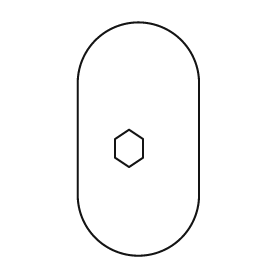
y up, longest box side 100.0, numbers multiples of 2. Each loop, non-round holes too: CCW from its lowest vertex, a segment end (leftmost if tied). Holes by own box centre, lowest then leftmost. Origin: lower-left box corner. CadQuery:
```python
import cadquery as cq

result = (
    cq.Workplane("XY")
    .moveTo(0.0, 26.0)
    .threePointArc((26.0, 0.0), (52.0, 26.0))
    .lineTo(52.0, 74.0)
    .threePointArc((26.0, 100.0), (0.0, 74.0))
    .close()
    .moveTo(22.0, 38.0)
    .lineTo(28.0, 42.0)
    .lineTo(28.0, 50.0)
    .lineTo(22.0, 54.0)
    .lineTo(16.0, 50.0)
    .lineTo(16.0, 42.0)
    .close()
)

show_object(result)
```